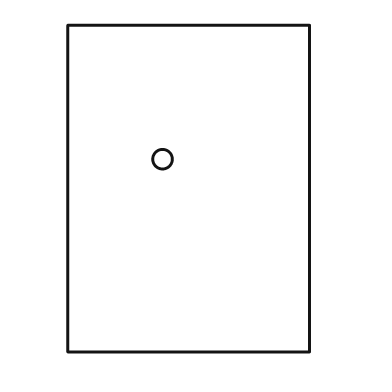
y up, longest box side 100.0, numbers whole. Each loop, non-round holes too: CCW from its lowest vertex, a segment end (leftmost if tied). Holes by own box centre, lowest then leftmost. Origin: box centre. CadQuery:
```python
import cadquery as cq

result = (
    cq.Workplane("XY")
    .moveTo(-37.0, -50.0)
    .lineTo(37.0, -50.0)
    .lineTo(37.0, 50.0)
    .lineTo(-37.0, 50.0)
    .close()
    .moveTo(-8.0, 9.0)
    .circle(3.0)
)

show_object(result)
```